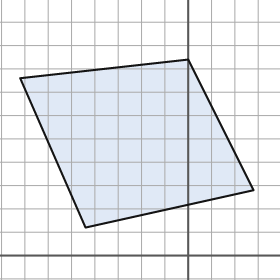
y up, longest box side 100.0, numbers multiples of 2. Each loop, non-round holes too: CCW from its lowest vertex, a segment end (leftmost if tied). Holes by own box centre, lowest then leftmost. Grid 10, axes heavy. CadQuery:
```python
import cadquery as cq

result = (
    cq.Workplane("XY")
    .moveTo(-44.0, 12.0)
    .lineTo(28.0, 28.0)
    .lineTo(0.0, 84.0)
    .lineTo(-72.0, 76.0)
    .close()
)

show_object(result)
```